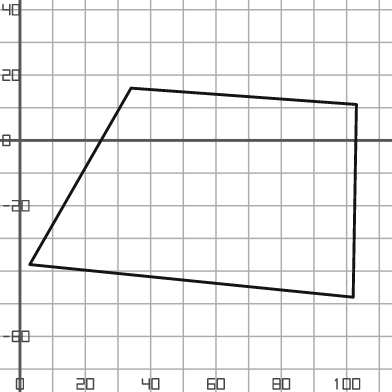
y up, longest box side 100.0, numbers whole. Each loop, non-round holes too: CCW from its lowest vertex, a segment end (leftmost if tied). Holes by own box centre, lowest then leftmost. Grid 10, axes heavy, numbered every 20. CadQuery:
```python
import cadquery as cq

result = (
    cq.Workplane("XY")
    .moveTo(102.0, -48.0)
    .lineTo(103.0, 11.0)
    .lineTo(34.0, 16.0)
    .lineTo(3.0, -38.0)
    .close()
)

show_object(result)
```